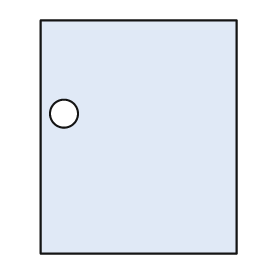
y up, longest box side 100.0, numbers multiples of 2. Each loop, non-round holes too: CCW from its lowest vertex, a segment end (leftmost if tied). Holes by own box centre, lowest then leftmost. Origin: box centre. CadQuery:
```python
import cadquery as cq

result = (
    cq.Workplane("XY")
    .moveTo(-42.0, -50.0)
    .lineTo(42.0, -50.0)
    .lineTo(42.0, 50.0)
    .lineTo(-42.0, 50.0)
    .close()
    .moveTo(-32.0, 10.0)
    .circle(6.0)
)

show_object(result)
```